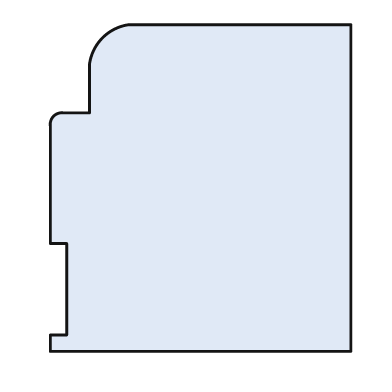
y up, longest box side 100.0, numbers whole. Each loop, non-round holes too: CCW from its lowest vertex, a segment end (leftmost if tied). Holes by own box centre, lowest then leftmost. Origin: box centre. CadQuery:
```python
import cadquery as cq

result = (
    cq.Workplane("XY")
    .moveTo(-46.0, -50.0)
    .lineTo(46.0, -50.0)
    .lineTo(46.0, 50.0)
    .lineTo(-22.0, 50.0)
    .threePointArc((-30.0, 46.0), (-34.0, 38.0))
    .lineTo(-34.0, 23.0)
    .lineTo(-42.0, 23.0)
    .threePointArc((-45.0, 22.0), (-46.0, 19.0))
    .lineTo(-46.0, -17.0)
    .lineTo(-41.0, -17.0)
    .lineTo(-41.0, -45.0)
    .lineTo(-46.0, -45.0)
    .close()
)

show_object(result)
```